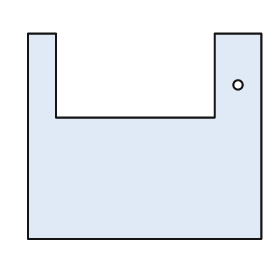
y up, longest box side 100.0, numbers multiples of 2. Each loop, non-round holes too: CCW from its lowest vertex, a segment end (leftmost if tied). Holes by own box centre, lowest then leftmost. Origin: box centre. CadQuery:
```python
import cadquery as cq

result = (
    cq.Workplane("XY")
    .moveTo(-50.0, -44.0)
    .lineTo(50.0, -44.0)
    .lineTo(50.0, 44.0)
    .lineTo(30.0, 44.0)
    .lineTo(30.0, 8.0)
    .lineTo(-38.0, 8.0)
    .lineTo(-38.0, 44.0)
    .lineTo(-50.0, 44.0)
    .close()
    .moveTo(40.0, 22.0)
    .circle(2.0)
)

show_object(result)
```